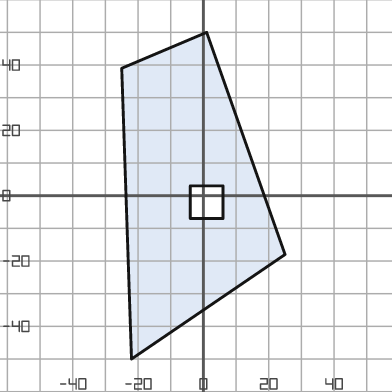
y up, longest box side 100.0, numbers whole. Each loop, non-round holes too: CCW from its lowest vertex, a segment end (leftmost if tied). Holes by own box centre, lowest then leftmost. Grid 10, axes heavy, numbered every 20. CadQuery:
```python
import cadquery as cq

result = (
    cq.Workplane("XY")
    .moveTo(-22.0, -50.0)
    .lineTo(25.0, -18.0)
    .lineTo(1.0, 50.0)
    .lineTo(-25.0, 39.0)
    .close()
    .moveTo(-4.0, -7.0)
    .lineTo(6.0, -7.0)
    .lineTo(6.0, 3.0)
    .lineTo(-4.0, 3.0)
    .close()
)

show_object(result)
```